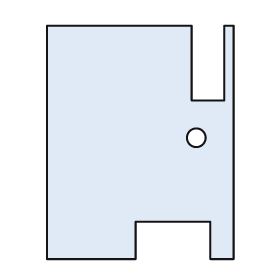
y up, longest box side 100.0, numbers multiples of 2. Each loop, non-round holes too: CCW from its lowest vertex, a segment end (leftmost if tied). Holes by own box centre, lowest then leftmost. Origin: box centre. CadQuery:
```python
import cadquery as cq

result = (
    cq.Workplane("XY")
    .moveTo(-40.0, -50.0)
    .lineTo(-2.0, -50.0)
    .lineTo(-2.0, -34.0)
    .lineTo(30.0, -34.0)
    .lineTo(30.0, -50.0)
    .lineTo(40.0, -50.0)
    .lineTo(40.0, 50.0)
    .lineTo(36.0, 50.0)
    .lineTo(36.0, 18.0)
    .lineTo(22.0, 18.0)
    .lineTo(22.0, 50.0)
    .lineTo(-40.0, 50.0)
    .close()
    .moveTo(24.0, 2.0)
    .circle(4.0)
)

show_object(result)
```